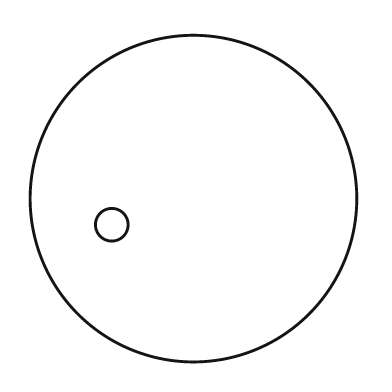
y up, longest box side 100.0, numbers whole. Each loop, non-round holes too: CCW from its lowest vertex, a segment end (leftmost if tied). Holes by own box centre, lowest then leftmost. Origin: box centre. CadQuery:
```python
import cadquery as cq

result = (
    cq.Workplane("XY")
    .moveTo(0.0, 0.0)
    .circle(50.0)
    .moveTo(-25.0, -8.0)
    .circle(5.0)
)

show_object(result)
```